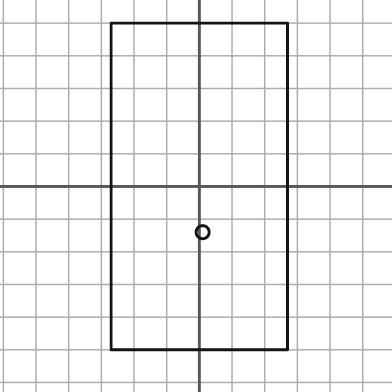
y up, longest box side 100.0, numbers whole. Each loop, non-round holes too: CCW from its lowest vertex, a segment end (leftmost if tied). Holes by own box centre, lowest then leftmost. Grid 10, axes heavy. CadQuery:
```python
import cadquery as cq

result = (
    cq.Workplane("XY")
    .moveTo(-27.0, -50.0)
    .lineTo(27.0, -50.0)
    .lineTo(27.0, 50.0)
    .lineTo(-27.0, 50.0)
    .close()
    .moveTo(1.0, -14.0)
    .circle(2.0)
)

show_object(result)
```